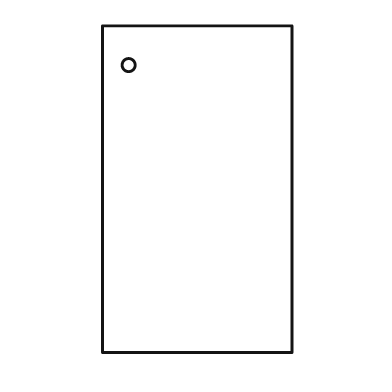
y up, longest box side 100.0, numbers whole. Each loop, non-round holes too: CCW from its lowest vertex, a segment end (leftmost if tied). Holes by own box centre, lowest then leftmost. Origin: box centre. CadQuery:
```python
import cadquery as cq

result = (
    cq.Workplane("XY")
    .moveTo(-29.0, -50.0)
    .lineTo(29.0, -50.0)
    .lineTo(29.0, 50.0)
    .lineTo(-29.0, 50.0)
    .close()
    .moveTo(-21.0, 38.0)
    .circle(2.0)
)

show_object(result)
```